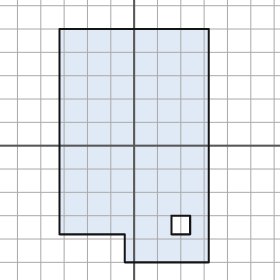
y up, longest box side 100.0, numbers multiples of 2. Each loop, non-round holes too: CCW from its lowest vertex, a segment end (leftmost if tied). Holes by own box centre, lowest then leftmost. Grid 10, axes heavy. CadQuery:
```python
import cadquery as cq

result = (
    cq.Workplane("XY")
    .moveTo(-4.0, -50.0)
    .lineTo(32.0, -50.0)
    .lineTo(32.0, 50.0)
    .lineTo(-32.0, 50.0)
    .lineTo(-32.0, -38.0)
    .lineTo(-4.0, -38.0)
    .close()
    .moveTo(16.0, -38.0)
    .lineTo(24.0, -38.0)
    .lineTo(24.0, -30.0)
    .lineTo(16.0, -30.0)
    .close()
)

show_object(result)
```